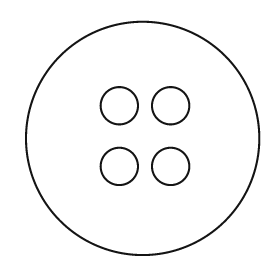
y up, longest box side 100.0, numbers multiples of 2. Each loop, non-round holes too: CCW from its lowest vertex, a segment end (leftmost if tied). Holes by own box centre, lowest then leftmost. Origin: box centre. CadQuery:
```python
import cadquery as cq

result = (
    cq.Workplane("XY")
    .moveTo(0.0, 0.0)
    .circle(50.0)
    .moveTo(-10.0, -12.0)
    .circle(8.0)
    .moveTo(12.0, -12.0)
    .circle(8.0)
    .moveTo(-10.0, 14.0)
    .circle(8.0)
    .moveTo(12.0, 14.0)
    .circle(8.0)
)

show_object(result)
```